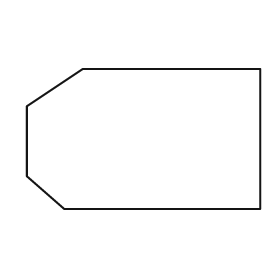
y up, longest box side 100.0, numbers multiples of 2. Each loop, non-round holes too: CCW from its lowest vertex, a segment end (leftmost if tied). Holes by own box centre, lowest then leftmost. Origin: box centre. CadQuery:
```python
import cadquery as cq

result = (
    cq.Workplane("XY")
    .moveTo(-34.0, -30.0)
    .lineTo(50.0, -30.0)
    .lineTo(50.0, 30.0)
    .lineTo(-26.0, 30.0)
    .lineTo(-50.0, 14.0)
    .lineTo(-50.0, -16.0)
    .close()
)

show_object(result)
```